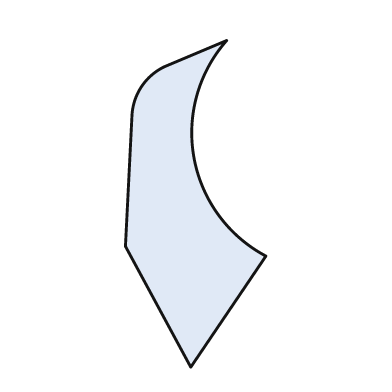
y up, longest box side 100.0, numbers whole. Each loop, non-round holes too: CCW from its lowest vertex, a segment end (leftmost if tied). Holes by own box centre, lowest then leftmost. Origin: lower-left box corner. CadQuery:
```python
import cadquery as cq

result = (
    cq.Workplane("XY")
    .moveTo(20.0, 0.0)
    .lineTo(43.0, 34.0)
    .threePointArc((21.0, 64.0), (31.0, 100.0))
    .lineTo(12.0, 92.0)
    .threePointArc((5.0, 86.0), (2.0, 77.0))
    .lineTo(0.0, 37.0)
    .close()
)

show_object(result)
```